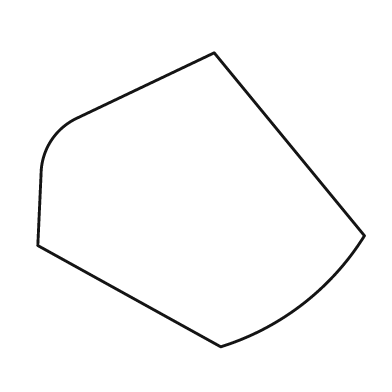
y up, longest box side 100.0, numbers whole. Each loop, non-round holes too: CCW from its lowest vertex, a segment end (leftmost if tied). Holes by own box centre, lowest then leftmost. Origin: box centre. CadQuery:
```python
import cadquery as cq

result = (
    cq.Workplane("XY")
    .moveTo(6.0, -45.0)
    .threePointArc((31.0, -32.0), (50.0, -11.0))
    .lineTo(4.0, 45.0)
    .lineTo(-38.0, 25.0)
    .threePointArc((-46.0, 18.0), (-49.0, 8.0))
    .lineTo(-50.0, -14.0)
    .close()
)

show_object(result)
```